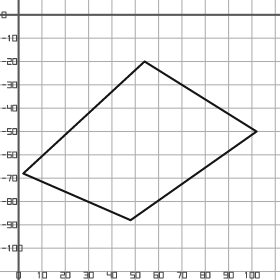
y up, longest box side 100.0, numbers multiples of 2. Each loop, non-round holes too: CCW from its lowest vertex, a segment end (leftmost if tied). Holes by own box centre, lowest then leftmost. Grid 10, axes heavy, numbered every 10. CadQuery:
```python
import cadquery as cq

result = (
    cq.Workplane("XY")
    .moveTo(48.0, -88.0)
    .lineTo(102.0, -50.0)
    .lineTo(54.0, -20.0)
    .lineTo(2.0, -68.0)
    .close()
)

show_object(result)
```